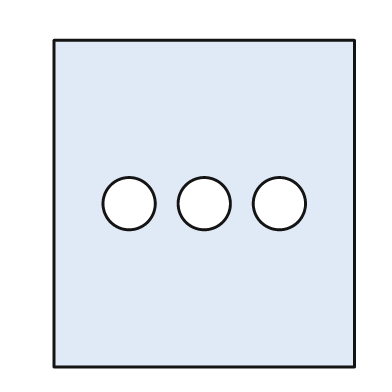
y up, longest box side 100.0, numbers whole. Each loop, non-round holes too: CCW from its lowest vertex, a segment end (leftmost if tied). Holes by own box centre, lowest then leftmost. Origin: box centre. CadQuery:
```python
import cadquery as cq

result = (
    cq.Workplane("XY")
    .moveTo(-46.0, -50.0)
    .lineTo(46.0, -50.0)
    .lineTo(46.0, 50.0)
    .lineTo(-46.0, 50.0)
    .close()
    .moveTo(-23.0, 0.0)
    .circle(8.0)
    .moveTo(0.0, 0.0)
    .circle(8.0)
    .moveTo(23.0, 0.0)
    .circle(8.0)
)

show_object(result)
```